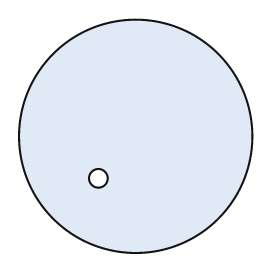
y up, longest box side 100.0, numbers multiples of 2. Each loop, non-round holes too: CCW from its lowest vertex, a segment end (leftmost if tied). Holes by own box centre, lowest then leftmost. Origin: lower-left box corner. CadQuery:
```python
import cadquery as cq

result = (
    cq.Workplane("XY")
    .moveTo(50.0, 50.0)
    .circle(50.0)
    .moveTo(34.0, 32.0)
    .circle(4.0)
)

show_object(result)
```